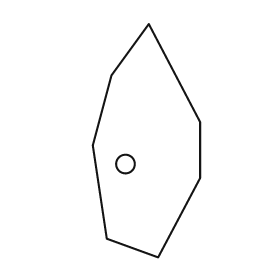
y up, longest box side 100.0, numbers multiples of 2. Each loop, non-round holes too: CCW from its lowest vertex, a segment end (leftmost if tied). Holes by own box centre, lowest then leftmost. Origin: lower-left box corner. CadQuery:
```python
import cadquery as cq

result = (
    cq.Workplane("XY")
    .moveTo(28.0, 0.0)
    .lineTo(46.0, 34.0)
    .lineTo(46.0, 58.0)
    .lineTo(24.0, 100.0)
    .lineTo(8.0, 78.0)
    .lineTo(0.0, 48.0)
    .lineTo(6.0, 8.0)
    .close()
    .moveTo(14.0, 40.0)
    .circle(4.0)
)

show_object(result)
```